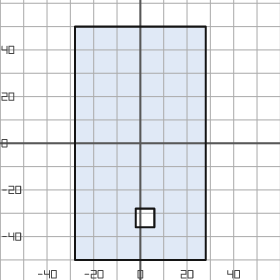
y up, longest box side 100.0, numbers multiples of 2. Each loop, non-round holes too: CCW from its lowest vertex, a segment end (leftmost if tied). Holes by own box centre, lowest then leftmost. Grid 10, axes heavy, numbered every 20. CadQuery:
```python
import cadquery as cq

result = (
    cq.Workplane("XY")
    .moveTo(-28.0, -50.0)
    .lineTo(28.0, -50.0)
    .lineTo(28.0, 50.0)
    .lineTo(-28.0, 50.0)
    .close()
    .moveTo(-2.0, -36.0)
    .lineTo(6.0, -36.0)
    .lineTo(6.0, -28.0)
    .lineTo(-2.0, -28.0)
    .close()
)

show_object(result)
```